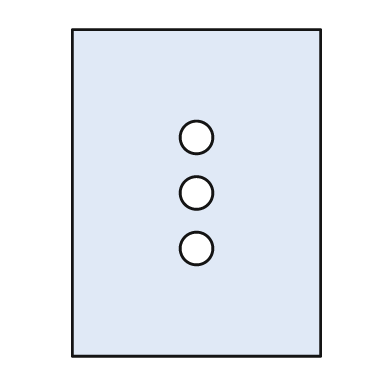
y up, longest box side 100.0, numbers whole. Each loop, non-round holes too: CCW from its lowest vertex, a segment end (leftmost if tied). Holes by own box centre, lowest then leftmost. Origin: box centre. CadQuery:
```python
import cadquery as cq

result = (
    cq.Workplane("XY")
    .moveTo(-38.0, -50.0)
    .lineTo(38.0, -50.0)
    .lineTo(38.0, 50.0)
    .lineTo(-38.0, 50.0)
    .close()
    .moveTo(0.0, -17.0)
    .circle(5.0)
    .moveTo(0.0, 0.0)
    .circle(5.0)
    .moveTo(0.0, 17.0)
    .circle(5.0)
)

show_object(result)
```